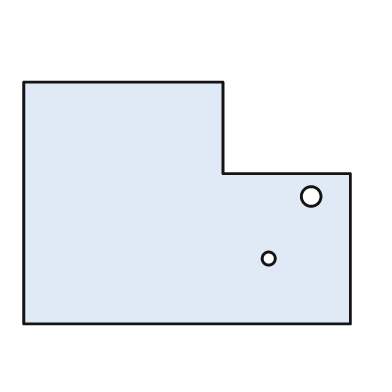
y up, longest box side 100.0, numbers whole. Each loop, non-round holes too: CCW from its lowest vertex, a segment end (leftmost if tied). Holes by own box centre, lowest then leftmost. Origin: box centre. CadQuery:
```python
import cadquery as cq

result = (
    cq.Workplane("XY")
    .moveTo(-50.0, -37.0)
    .lineTo(50.0, -37.0)
    .lineTo(50.0, 9.0)
    .lineTo(11.0, 9.0)
    .lineTo(11.0, 37.0)
    .lineTo(-50.0, 37.0)
    .close()
    .moveTo(25.0, -17.0)
    .circle(2.0)
    .moveTo(38.0, 2.0)
    .circle(3.0)
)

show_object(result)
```